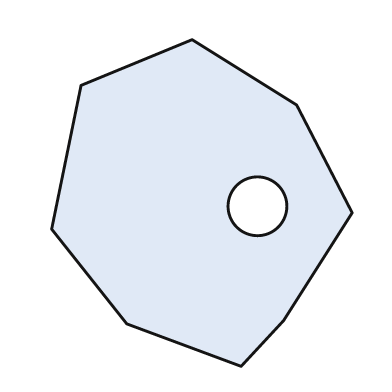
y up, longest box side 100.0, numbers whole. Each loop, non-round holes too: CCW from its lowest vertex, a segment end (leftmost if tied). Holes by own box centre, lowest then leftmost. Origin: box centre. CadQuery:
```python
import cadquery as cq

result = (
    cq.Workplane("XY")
    .moveTo(12.0, -50.0)
    .lineTo(25.0, -36.0)
    .lineTo(46.0, -3.0)
    .lineTo(29.0, 30.0)
    .lineTo(-3.0, 50.0)
    .lineTo(-37.0, 36.0)
    .lineTo(-46.0, -8.0)
    .lineTo(-23.0, -37.0)
    .close()
    .moveTo(17.0, -1.0)
    .circle(9.0)
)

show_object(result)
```